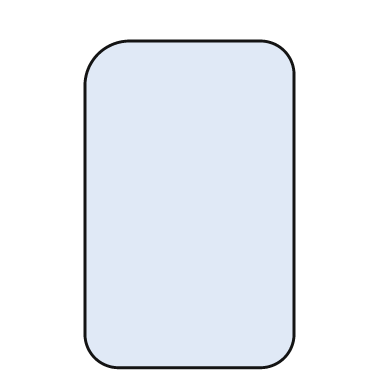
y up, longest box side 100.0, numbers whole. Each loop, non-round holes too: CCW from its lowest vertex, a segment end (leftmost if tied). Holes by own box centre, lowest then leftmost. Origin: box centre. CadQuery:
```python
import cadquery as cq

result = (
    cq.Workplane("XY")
    .moveTo(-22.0, -50.0)
    .lineTo(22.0, -50.0)
    .threePointArc((29.0, -47.0), (32.0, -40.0))
    .lineTo(32.0, 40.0)
    .threePointArc((29.0, 47.0), (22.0, 50.0))
    .lineTo(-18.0, 50.0)
    .threePointArc((-28.0, 46.0), (-32.0, 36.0))
    .lineTo(-32.0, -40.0)
    .threePointArc((-29.0, -47.0), (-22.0, -50.0))
    .close()
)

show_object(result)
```